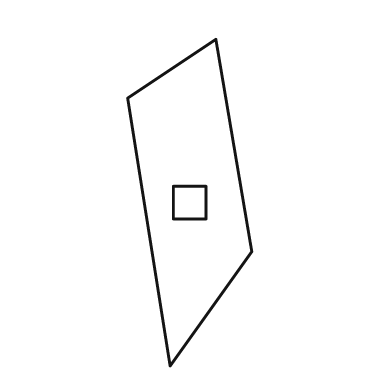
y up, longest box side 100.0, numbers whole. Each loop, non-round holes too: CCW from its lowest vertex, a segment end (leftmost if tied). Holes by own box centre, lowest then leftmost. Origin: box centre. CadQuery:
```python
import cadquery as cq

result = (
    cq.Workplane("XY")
    .moveTo(-6.0, -50.0)
    .lineTo(19.0, -15.0)
    .lineTo(8.0, 50.0)
    .lineTo(-19.0, 32.0)
    .close()
    .moveTo(-5.0, -5.0)
    .lineTo(5.0, -5.0)
    .lineTo(5.0, 5.0)
    .lineTo(-5.0, 5.0)
    .close()
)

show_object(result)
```